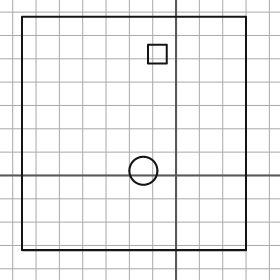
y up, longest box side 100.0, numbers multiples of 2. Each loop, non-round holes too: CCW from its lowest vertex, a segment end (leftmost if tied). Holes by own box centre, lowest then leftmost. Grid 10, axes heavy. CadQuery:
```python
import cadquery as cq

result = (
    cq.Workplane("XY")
    .moveTo(-66.0, -32.0)
    .lineTo(30.0, -32.0)
    .lineTo(30.0, 68.0)
    .lineTo(-66.0, 68.0)
    .close()
    .moveTo(-14.0, 2.0)
    .circle(6.0)
    .moveTo(-12.0, 48.0)
    .lineTo(-4.0, 48.0)
    .lineTo(-4.0, 56.0)
    .lineTo(-12.0, 56.0)
    .close()
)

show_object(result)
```